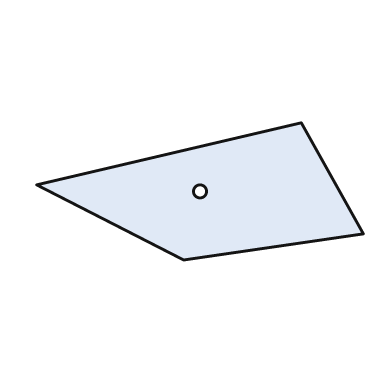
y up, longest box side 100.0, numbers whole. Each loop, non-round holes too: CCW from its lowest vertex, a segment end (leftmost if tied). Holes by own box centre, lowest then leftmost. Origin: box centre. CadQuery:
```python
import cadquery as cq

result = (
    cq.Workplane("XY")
    .moveTo(-5.0, -21.0)
    .lineTo(50.0, -13.0)
    .lineTo(31.0, 21.0)
    .lineTo(-50.0, 2.0)
    .close()
    .moveTo(0.0, 0.0)
    .circle(2.0)
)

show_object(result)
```